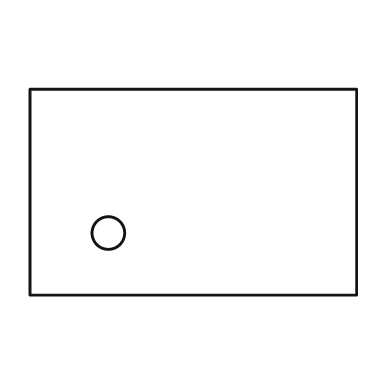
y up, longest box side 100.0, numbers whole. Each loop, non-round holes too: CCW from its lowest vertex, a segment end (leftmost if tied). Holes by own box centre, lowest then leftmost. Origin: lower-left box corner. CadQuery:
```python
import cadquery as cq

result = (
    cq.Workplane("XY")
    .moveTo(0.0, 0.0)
    .lineTo(100.0, 0.0)
    .lineTo(100.0, 63.0)
    .lineTo(0.0, 63.0)
    .close()
    .moveTo(24.0, 19.0)
    .circle(5.0)
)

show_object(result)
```